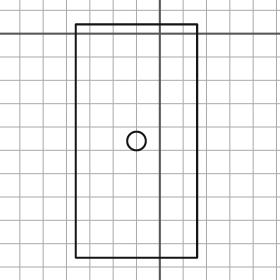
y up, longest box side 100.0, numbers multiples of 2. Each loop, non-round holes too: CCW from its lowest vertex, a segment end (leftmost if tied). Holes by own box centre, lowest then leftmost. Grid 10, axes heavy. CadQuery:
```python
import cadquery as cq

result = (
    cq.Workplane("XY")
    .moveTo(-36.0, -96.0)
    .lineTo(16.0, -96.0)
    .lineTo(16.0, 4.0)
    .lineTo(-36.0, 4.0)
    .close()
    .moveTo(-10.0, -46.0)
    .circle(4.0)
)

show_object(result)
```